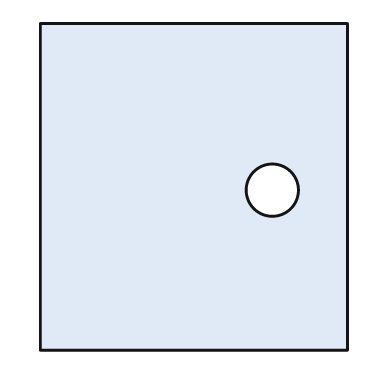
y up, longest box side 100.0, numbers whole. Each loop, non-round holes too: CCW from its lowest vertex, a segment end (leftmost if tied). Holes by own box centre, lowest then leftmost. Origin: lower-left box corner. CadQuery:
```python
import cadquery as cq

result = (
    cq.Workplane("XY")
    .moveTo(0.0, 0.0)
    .lineTo(94.0, 0.0)
    .lineTo(94.0, 100.0)
    .lineTo(0.0, 100.0)
    .close()
    .moveTo(71.0, 49.0)
    .circle(8.0)
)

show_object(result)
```